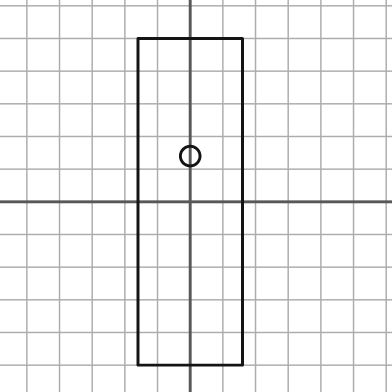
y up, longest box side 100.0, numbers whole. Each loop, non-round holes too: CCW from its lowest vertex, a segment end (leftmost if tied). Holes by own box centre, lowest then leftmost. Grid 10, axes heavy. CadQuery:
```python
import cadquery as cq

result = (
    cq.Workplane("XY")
    .moveTo(-16.0, -50.0)
    .lineTo(16.0, -50.0)
    .lineTo(16.0, 50.0)
    .lineTo(-16.0, 50.0)
    .close()
    .moveTo(0.0, 14.0)
    .circle(3.0)
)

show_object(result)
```